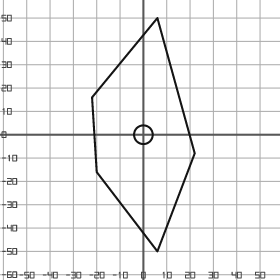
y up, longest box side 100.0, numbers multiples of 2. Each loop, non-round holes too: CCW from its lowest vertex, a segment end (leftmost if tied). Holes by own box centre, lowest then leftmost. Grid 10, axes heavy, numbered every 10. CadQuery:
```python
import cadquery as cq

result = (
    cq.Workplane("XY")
    .moveTo(6.0, -50.0)
    .lineTo(22.0, -8.0)
    .lineTo(6.0, 50.0)
    .lineTo(-22.0, 16.0)
    .lineTo(-20.0, -16.0)
    .close()
    .moveTo(0.0, 0.0)
    .circle(4.0)
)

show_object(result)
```